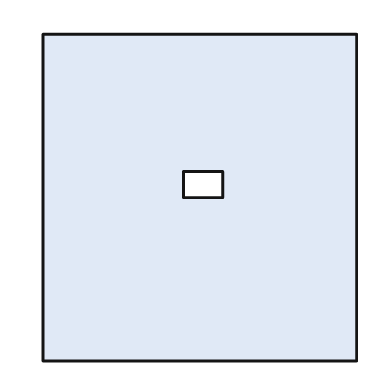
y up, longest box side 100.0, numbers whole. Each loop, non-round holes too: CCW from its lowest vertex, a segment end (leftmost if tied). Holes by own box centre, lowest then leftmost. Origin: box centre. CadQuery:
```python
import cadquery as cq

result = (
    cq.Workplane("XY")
    .moveTo(-48.0, -50.0)
    .lineTo(48.0, -50.0)
    .lineTo(48.0, 50.0)
    .lineTo(-48.0, 50.0)
    .close()
    .moveTo(-5.0, 0.0)
    .lineTo(7.0, 0.0)
    .lineTo(7.0, 8.0)
    .lineTo(-5.0, 8.0)
    .close()
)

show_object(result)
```